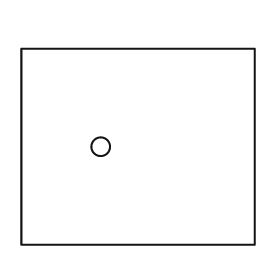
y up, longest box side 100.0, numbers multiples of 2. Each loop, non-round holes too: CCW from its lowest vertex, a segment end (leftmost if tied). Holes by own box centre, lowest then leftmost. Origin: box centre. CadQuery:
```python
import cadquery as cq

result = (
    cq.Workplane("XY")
    .moveTo(-50.0, -42.0)
    .lineTo(50.0, -42.0)
    .lineTo(50.0, 42.0)
    .lineTo(-50.0, 42.0)
    .close()
    .moveTo(-16.0, 0.0)
    .circle(4.0)
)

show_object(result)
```